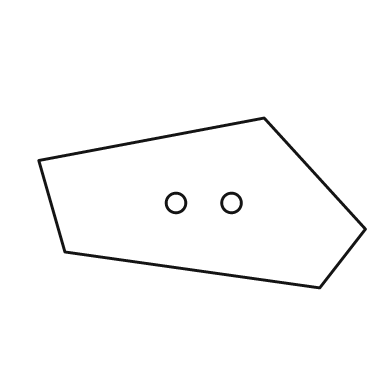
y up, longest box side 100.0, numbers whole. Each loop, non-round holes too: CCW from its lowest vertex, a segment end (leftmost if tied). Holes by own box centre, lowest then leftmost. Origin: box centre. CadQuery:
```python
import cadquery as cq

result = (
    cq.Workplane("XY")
    .moveTo(36.0, -26.0)
    .lineTo(50.0, -8.0)
    .lineTo(19.0, 26.0)
    .lineTo(-50.0, 13.0)
    .lineTo(-42.0, -15.0)
    .close()
    .moveTo(-8.0, 0.0)
    .circle(3.0)
    .moveTo(9.0, 0.0)
    .circle(3.0)
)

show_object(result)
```